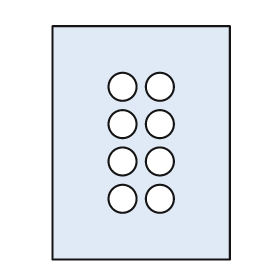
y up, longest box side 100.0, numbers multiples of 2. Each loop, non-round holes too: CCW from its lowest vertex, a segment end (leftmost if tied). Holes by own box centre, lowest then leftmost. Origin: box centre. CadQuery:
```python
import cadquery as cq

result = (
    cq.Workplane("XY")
    .moveTo(-38.0, -50.0)
    .lineTo(38.0, -50.0)
    .lineTo(38.0, 50.0)
    .lineTo(-38.0, 50.0)
    .close()
    .moveTo(-8.0, -24.0)
    .circle(6.0)
    .moveTo(8.0, -24.0)
    .circle(6.0)
    .moveTo(-8.0, -8.0)
    .circle(6.0)
    .moveTo(8.0, -8.0)
    .circle(6.0)
    .moveTo(-8.0, 8.0)
    .circle(6.0)
    .moveTo(8.0, 8.0)
    .circle(6.0)
    .moveTo(-8.0, 24.0)
    .circle(6.0)
    .moveTo(8.0, 24.0)
    .circle(6.0)
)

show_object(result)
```